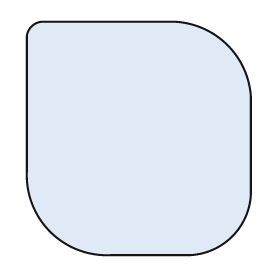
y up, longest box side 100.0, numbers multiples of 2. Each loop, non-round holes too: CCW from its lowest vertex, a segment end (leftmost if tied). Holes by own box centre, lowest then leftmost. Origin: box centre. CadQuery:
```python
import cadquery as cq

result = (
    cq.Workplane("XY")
    .moveTo(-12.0, -50.0)
    .lineTo(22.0, -50.0)
    .threePointArc((40.0, -42.0), (48.0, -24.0))
    .lineTo(48.0, 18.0)
    .threePointArc((38.0, 40.0), (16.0, 50.0))
    .lineTo(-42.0, 50.0)
    .threePointArc((-46.0, 48.0), (-48.0, 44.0))
    .lineTo(-48.0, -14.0)
    .threePointArc((-38.0, -40.0), (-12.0, -50.0))
    .close()
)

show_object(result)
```